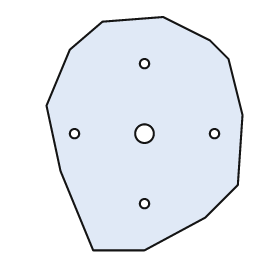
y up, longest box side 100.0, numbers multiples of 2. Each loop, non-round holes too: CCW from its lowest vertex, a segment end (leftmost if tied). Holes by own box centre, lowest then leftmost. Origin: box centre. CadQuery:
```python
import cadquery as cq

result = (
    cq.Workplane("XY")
    .moveTo(-22.0, -50.0)
    .lineTo(0.0, -50.0)
    .lineTo(26.0, -36.0)
    .lineTo(40.0, -22.0)
    .lineTo(42.0, 8.0)
    .lineTo(36.0, 32.0)
    .lineTo(28.0, 40.0)
    .lineTo(8.0, 50.0)
    .lineTo(-18.0, 48.0)
    .lineTo(-32.0, 36.0)
    .lineTo(-42.0, 12.0)
    .lineTo(-36.0, -16.0)
    .close()
    .moveTo(0.0, -30.0)
    .circle(2.0)
    .moveTo(-30.0, 0.0)
    .circle(2.0)
    .moveTo(0.0, 0.0)
    .circle(4.0)
    .moveTo(30.0, 0.0)
    .circle(2.0)
    .moveTo(0.0, 30.0)
    .circle(2.0)
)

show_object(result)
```